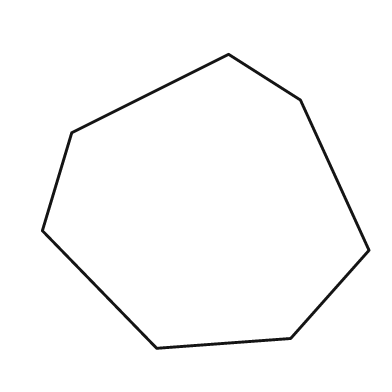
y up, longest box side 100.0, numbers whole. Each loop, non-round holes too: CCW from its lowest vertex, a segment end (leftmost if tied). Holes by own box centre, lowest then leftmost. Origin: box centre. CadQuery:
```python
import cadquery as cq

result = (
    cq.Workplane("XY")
    .moveTo(-15.0, -45.0)
    .lineTo(26.0, -42.0)
    .lineTo(50.0, -15.0)
    .lineTo(29.0, 31.0)
    .lineTo(7.0, 45.0)
    .lineTo(-41.0, 21.0)
    .lineTo(-50.0, -9.0)
    .close()
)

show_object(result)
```